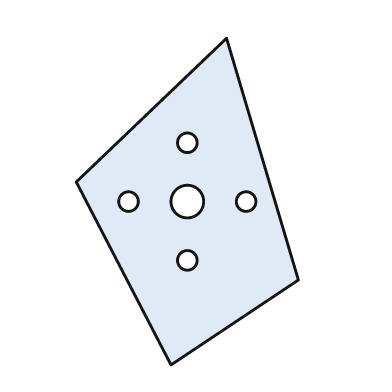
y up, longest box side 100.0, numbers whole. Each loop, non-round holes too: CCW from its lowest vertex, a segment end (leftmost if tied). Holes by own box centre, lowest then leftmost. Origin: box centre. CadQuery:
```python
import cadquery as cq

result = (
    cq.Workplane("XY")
    .moveTo(-5.0, -50.0)
    .lineTo(34.0, -24.0)
    .lineTo(12.0, 50.0)
    .lineTo(-34.0, 6.0)
    .close()
    .moveTo(0.0, -18.0)
    .circle(3.0)
    .moveTo(-18.0, 0.0)
    .circle(3.0)
    .moveTo(0.0, 0.0)
    .circle(5.0)
    .moveTo(18.0, 0.0)
    .circle(3.0)
    .moveTo(0.0, 18.0)
    .circle(3.0)
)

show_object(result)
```